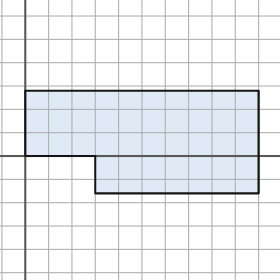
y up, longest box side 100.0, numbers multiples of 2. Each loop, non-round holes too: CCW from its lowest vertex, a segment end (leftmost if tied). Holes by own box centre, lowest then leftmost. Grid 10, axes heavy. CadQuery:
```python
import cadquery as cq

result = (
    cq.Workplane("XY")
    .moveTo(30.0, -16.0)
    .lineTo(100.0, -16.0)
    .lineTo(100.0, 28.0)
    .lineTo(0.0, 28.0)
    .lineTo(0.0, 0.0)
    .lineTo(30.0, 0.0)
    .close()
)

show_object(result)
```